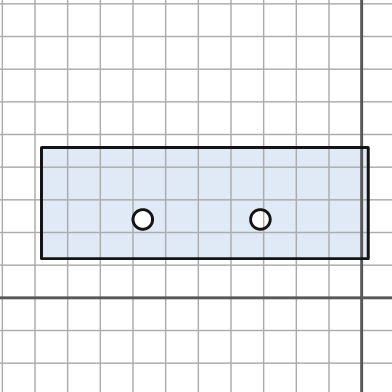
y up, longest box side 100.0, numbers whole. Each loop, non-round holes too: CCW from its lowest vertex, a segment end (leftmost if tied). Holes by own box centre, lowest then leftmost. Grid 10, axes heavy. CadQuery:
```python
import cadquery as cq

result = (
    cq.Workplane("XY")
    .moveTo(-98.0, 12.0)
    .lineTo(2.0, 12.0)
    .lineTo(2.0, 46.0)
    .lineTo(-98.0, 46.0)
    .close()
    .moveTo(-67.0, 24.0)
    .circle(3.0)
    .moveTo(-31.0, 24.0)
    .circle(3.0)
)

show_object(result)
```